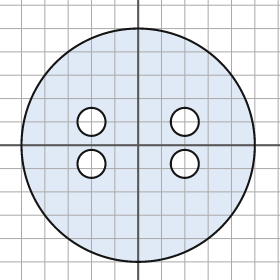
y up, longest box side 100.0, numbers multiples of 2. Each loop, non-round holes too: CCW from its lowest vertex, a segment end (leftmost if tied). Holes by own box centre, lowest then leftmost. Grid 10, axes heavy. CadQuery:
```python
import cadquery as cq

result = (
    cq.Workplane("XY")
    .moveTo(0.0, 0.0)
    .circle(50.0)
    .moveTo(-20.0, -8.0)
    .circle(6.0)
    .moveTo(20.0, -8.0)
    .circle(6.0)
    .moveTo(-20.0, 10.0)
    .circle(6.0)
    .moveTo(20.0, 10.0)
    .circle(6.0)
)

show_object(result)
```